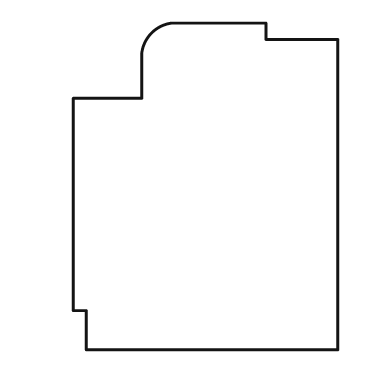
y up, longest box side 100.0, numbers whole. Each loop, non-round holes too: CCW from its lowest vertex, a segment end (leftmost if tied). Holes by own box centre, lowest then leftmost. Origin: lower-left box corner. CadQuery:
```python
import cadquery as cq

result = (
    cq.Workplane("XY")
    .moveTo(4.0, 0.0)
    .lineTo(81.0, 0.0)
    .lineTo(81.0, 95.0)
    .lineTo(59.0, 95.0)
    .lineTo(59.0, 100.0)
    .lineTo(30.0, 100.0)
    .threePointArc((24.0, 97.0), (21.0, 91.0))
    .lineTo(21.0, 77.0)
    .lineTo(0.0, 77.0)
    .lineTo(0.0, 12.0)
    .lineTo(4.0, 12.0)
    .close()
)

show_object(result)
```